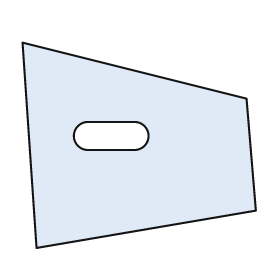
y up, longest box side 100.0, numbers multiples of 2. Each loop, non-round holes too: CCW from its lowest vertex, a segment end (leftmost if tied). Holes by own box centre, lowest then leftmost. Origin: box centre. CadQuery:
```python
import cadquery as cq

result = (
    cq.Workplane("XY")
    .moveTo(-44.0, -44.0)
    .lineTo(50.0, -28.0)
    .lineTo(46.0, 20.0)
    .lineTo(-50.0, 44.0)
    .close()
    .moveTo(-22.0, -2.0)
    .lineTo(-2.0, -2.0)
    .threePointArc((4.0, 4.0), (-2.0, 10.0))
    .lineTo(-22.0, 10.0)
    .threePointArc((-28.0, 4.0), (-22.0, -2.0))
    .close()
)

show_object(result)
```